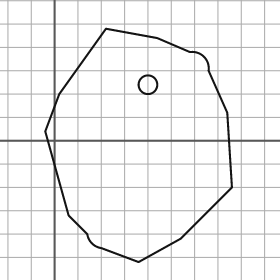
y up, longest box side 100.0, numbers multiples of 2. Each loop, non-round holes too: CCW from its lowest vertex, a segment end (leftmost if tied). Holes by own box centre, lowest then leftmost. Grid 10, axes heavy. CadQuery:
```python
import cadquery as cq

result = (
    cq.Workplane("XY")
    .moveTo(36.0, -52.0)
    .lineTo(54.0, -42.0)
    .lineTo(76.0, -20.0)
    .lineTo(74.0, 12.0)
    .lineTo(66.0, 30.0)
    .threePointArc((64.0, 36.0), (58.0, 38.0))
    .lineTo(44.0, 44.0)
    .lineTo(22.0, 48.0)
    .lineTo(2.0, 20.0)
    .lineTo(-4.0, 4.0)
    .lineTo(6.0, -32.0)
    .lineTo(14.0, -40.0)
    .threePointArc((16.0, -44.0), (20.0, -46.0))
    .close()
    .moveTo(40.0, 24.0)
    .circle(4.0)
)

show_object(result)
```